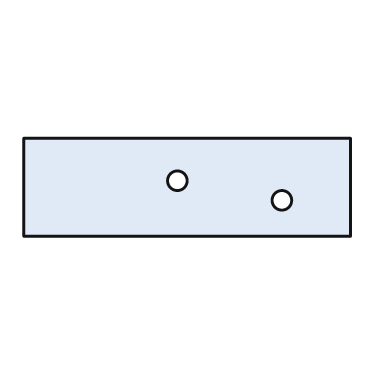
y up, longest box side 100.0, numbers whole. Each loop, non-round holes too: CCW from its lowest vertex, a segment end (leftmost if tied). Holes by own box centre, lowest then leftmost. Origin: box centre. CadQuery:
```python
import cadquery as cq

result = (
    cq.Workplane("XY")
    .moveTo(-50.0, -15.0)
    .lineTo(50.0, -15.0)
    .lineTo(50.0, 15.0)
    .lineTo(-50.0, 15.0)
    .close()
    .moveTo(29.0, -4.0)
    .circle(3.0)
    .moveTo(-3.0, 2.0)
    .circle(3.0)
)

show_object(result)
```